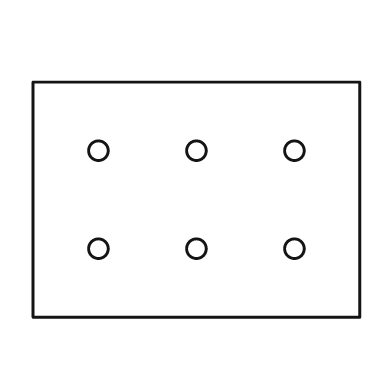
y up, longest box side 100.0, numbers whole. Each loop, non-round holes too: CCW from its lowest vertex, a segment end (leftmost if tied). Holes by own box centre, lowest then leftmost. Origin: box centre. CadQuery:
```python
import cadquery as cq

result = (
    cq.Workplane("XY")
    .moveTo(-50.0, -36.0)
    .lineTo(50.0, -36.0)
    .lineTo(50.0, 36.0)
    .lineTo(-50.0, 36.0)
    .close()
    .moveTo(-30.0, -15.0)
    .circle(3.0)
    .moveTo(0.0, -15.0)
    .circle(3.0)
    .moveTo(30.0, -15.0)
    .circle(3.0)
    .moveTo(-30.0, 15.0)
    .circle(3.0)
    .moveTo(0.0, 15.0)
    .circle(3.0)
    .moveTo(30.0, 15.0)
    .circle(3.0)
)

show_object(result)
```